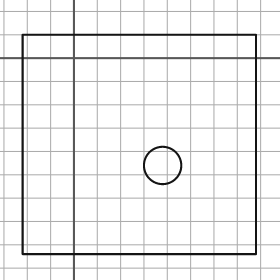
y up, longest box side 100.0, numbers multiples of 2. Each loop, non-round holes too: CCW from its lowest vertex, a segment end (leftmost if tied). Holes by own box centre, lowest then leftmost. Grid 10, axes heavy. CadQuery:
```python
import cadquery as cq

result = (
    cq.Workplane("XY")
    .moveTo(-22.0, -84.0)
    .lineTo(78.0, -84.0)
    .lineTo(78.0, 10.0)
    .lineTo(-22.0, 10.0)
    .close()
    .moveTo(38.0, -46.0)
    .circle(8.0)
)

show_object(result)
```